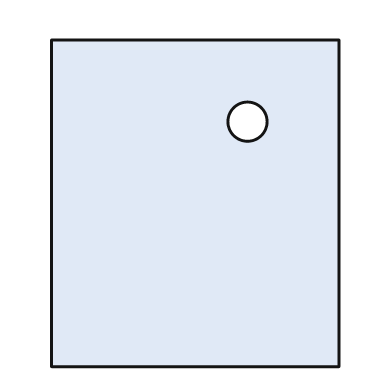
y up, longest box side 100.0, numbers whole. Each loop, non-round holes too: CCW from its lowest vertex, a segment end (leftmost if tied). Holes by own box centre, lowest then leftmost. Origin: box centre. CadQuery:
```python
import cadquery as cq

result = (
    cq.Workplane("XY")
    .moveTo(-44.0, -50.0)
    .lineTo(44.0, -50.0)
    .lineTo(44.0, 50.0)
    .lineTo(-44.0, 50.0)
    .close()
    .moveTo(16.0, 25.0)
    .circle(6.0)
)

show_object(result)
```